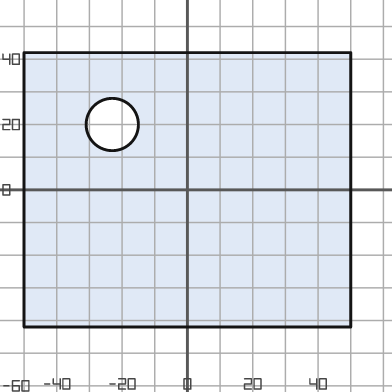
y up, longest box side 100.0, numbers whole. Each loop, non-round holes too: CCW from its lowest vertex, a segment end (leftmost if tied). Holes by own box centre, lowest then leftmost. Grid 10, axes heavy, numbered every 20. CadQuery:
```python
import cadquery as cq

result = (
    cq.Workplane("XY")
    .moveTo(-50.0, -42.0)
    .lineTo(50.0, -42.0)
    .lineTo(50.0, 42.0)
    .lineTo(-50.0, 42.0)
    .close()
    .moveTo(-23.0, 20.0)
    .circle(8.0)
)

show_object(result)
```